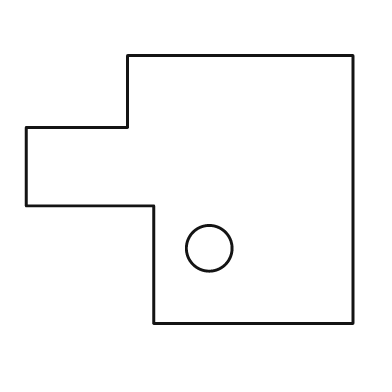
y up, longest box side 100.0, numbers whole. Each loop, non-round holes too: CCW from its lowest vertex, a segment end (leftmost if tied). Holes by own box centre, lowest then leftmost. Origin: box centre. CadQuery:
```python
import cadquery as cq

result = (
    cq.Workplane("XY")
    .moveTo(-11.0, -41.0)
    .lineTo(50.0, -41.0)
    .lineTo(50.0, 41.0)
    .lineTo(-19.0, 41.0)
    .lineTo(-19.0, 19.0)
    .lineTo(-50.0, 19.0)
    .lineTo(-50.0, -5.0)
    .lineTo(-11.0, -5.0)
    .close()
    .moveTo(6.0, -18.0)
    .circle(7.0)
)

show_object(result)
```